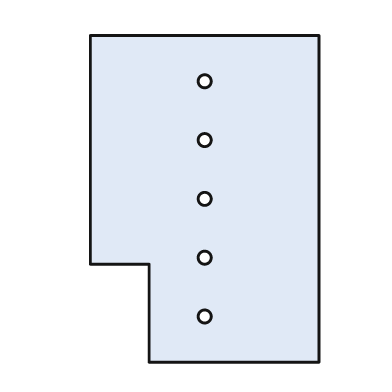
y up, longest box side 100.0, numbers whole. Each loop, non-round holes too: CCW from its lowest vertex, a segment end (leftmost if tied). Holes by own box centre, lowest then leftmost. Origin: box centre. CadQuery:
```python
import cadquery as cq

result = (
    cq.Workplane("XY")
    .moveTo(-17.0, -50.0)
    .lineTo(35.0, -50.0)
    .lineTo(35.0, 50.0)
    .lineTo(-35.0, 50.0)
    .lineTo(-35.0, -20.0)
    .lineTo(-17.0, -20.0)
    .close()
    .moveTo(0.0, -36.0)
    .circle(2.0)
    .moveTo(0.0, -18.0)
    .circle(2.0)
    .moveTo(0.0, 0.0)
    .circle(2.0)
    .moveTo(0.0, 18.0)
    .circle(2.0)
    .moveTo(0.0, 36.0)
    .circle(2.0)
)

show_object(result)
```